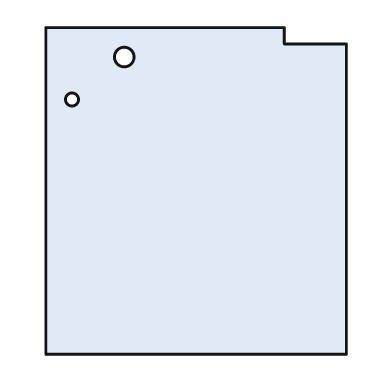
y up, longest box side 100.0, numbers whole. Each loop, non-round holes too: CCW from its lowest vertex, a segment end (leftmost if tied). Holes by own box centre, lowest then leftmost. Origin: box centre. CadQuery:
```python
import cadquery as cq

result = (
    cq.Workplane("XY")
    .moveTo(-46.0, -50.0)
    .lineTo(46.0, -50.0)
    .lineTo(46.0, 45.0)
    .lineTo(27.0, 45.0)
    .lineTo(27.0, 50.0)
    .lineTo(-46.0, 50.0)
    .close()
    .moveTo(-38.0, 28.0)
    .circle(2.0)
    .moveTo(-22.0, 41.0)
    .circle(3.0)
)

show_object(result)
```